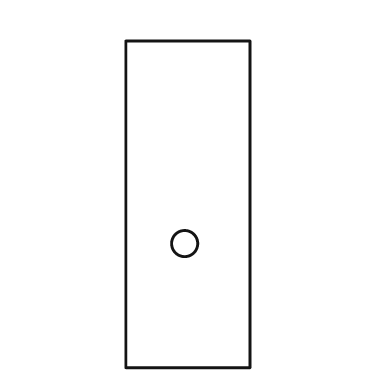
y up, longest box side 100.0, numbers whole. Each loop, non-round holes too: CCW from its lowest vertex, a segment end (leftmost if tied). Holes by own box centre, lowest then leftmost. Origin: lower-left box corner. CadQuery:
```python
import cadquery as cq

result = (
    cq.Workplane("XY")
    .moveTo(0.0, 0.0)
    .lineTo(38.0, 0.0)
    .lineTo(38.0, 100.0)
    .lineTo(0.0, 100.0)
    .close()
    .moveTo(18.0, 38.0)
    .circle(4.0)
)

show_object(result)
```